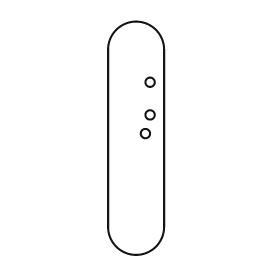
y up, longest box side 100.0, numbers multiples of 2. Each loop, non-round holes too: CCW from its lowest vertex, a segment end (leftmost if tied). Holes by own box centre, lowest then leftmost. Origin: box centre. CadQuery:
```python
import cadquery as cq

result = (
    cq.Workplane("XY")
    .moveTo(-12.0, -38.0)
    .threePointArc((0.0, -50.0), (12.0, -38.0))
    .lineTo(12.0, 38.0)
    .threePointArc((0.0, 50.0), (-12.0, 38.0))
    .close()
    .moveTo(4.0, 2.0)
    .circle(2.0)
    .moveTo(6.0, 10.0)
    .circle(2.0)
    .moveTo(6.0, 24.0)
    .circle(2.0)
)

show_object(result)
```